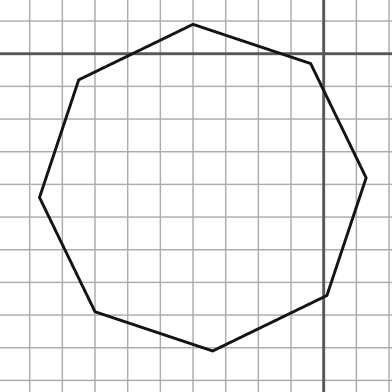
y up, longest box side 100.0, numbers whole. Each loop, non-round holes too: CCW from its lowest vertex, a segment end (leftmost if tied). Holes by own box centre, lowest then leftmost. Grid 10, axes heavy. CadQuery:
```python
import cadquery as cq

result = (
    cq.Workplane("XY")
    .moveTo(-34.0, -91.0)
    .lineTo(1.0, -74.0)
    .lineTo(13.0, -38.0)
    .lineTo(-4.0, -3.0)
    .lineTo(-40.0, 9.0)
    .lineTo(-75.0, -8.0)
    .lineTo(-87.0, -44.0)
    .lineTo(-70.0, -79.0)
    .close()
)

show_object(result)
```